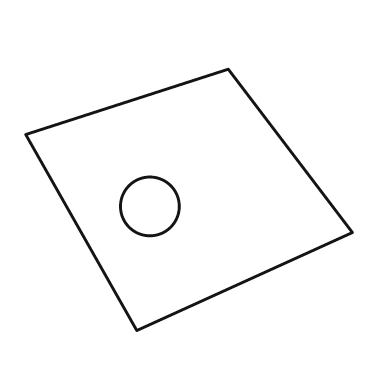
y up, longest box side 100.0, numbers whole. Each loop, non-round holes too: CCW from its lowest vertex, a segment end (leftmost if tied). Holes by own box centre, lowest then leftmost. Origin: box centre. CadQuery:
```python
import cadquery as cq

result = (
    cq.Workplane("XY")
    .moveTo(-16.0, -40.0)
    .lineTo(50.0, -10.0)
    .lineTo(12.0, 40.0)
    .lineTo(-50.0, 20.0)
    .close()
    .moveTo(-12.0, -2.0)
    .circle(9.0)
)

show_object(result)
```